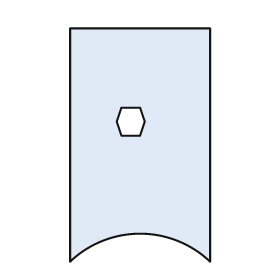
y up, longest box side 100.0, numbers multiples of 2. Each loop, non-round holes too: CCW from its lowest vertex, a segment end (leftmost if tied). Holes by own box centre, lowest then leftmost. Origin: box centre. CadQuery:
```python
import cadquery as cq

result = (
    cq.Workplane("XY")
    .moveTo(-30.0, -50.0)
    .threePointArc((0.0, -38.0), (30.0, -50.0))
    .lineTo(30.0, 50.0)
    .lineTo(-30.0, 50.0)
    .close()
    .moveTo(-8.0, 4.0)
    .lineTo(0.0, 4.0)
    .lineTo(2.0, 10.0)
    .lineTo(0.0, 16.0)
    .lineTo(-8.0, 16.0)
    .lineTo(-10.0, 10.0)
    .close()
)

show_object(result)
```